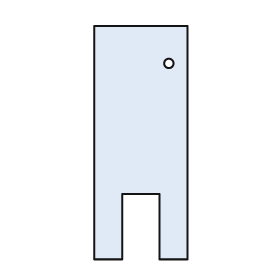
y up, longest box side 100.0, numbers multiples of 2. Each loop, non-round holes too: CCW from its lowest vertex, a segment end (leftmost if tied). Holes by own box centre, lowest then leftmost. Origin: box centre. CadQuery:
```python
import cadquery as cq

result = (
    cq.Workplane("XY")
    .moveTo(-20.0, -50.0)
    .lineTo(-8.0, -50.0)
    .lineTo(-8.0, -22.0)
    .lineTo(8.0, -22.0)
    .lineTo(8.0, -50.0)
    .lineTo(20.0, -50.0)
    .lineTo(20.0, 50.0)
    .lineTo(-20.0, 50.0)
    .close()
    .moveTo(12.0, 34.0)
    .circle(2.0)
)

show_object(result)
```